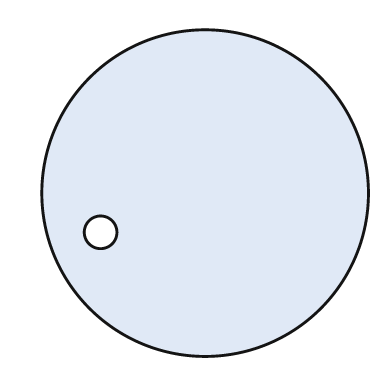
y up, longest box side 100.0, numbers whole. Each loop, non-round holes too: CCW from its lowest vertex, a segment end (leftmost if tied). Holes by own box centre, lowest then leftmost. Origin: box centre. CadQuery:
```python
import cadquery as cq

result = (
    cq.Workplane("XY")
    .moveTo(0.0, 0.0)
    .circle(50.0)
    .moveTo(-32.0, -12.0)
    .circle(5.0)
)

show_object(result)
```